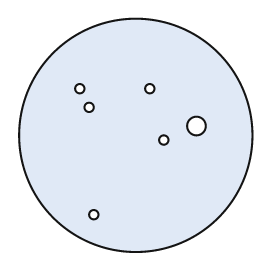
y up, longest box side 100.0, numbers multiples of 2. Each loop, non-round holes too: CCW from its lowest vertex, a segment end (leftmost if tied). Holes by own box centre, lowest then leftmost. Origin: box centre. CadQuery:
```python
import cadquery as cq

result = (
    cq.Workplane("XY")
    .moveTo(0.0, 0.0)
    .circle(50.0)
    .moveTo(-18.0, -34.0)
    .circle(2.0)
    .moveTo(12.0, -2.0)
    .circle(2.0)
    .moveTo(26.0, 4.0)
    .circle(4.0)
    .moveTo(-20.0, 12.0)
    .circle(2.0)
    .moveTo(-24.0, 20.0)
    .circle(2.0)
    .moveTo(6.0, 20.0)
    .circle(2.0)
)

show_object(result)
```